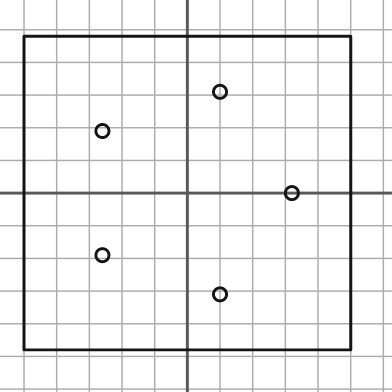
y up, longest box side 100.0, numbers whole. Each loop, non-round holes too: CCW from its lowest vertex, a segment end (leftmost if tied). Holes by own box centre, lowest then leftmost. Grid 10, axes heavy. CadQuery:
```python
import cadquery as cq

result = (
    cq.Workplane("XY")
    .moveTo(-50.0, -48.0)
    .lineTo(50.0, -48.0)
    .lineTo(50.0, 48.0)
    .lineTo(-50.0, 48.0)
    .close()
    .moveTo(10.0, -31.0)
    .circle(2.0)
    .moveTo(-26.0, -19.0)
    .circle(2.0)
    .moveTo(32.0, 0.0)
    .circle(2.0)
    .moveTo(-26.0, 19.0)
    .circle(2.0)
    .moveTo(10.0, 31.0)
    .circle(2.0)
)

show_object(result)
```